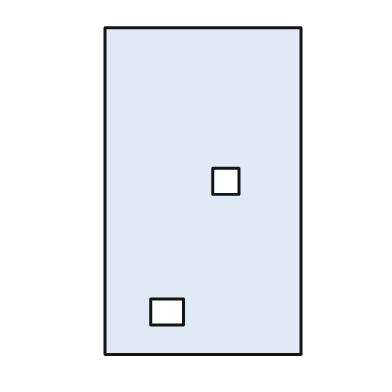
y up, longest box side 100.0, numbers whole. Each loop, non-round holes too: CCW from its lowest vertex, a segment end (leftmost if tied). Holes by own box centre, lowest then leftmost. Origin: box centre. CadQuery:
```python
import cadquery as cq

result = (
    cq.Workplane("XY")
    .moveTo(-30.0, -50.0)
    .lineTo(30.0, -50.0)
    .lineTo(30.0, 50.0)
    .lineTo(-30.0, 50.0)
    .close()
    .moveTo(-16.0, -41.0)
    .lineTo(-6.0, -41.0)
    .lineTo(-6.0, -33.0)
    .lineTo(-16.0, -33.0)
    .close()
    .moveTo(3.0, -1.0)
    .lineTo(11.0, -1.0)
    .lineTo(11.0, 7.0)
    .lineTo(3.0, 7.0)
    .close()
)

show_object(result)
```